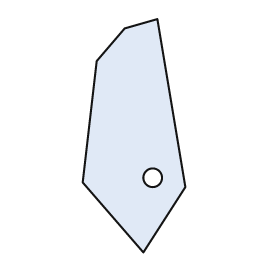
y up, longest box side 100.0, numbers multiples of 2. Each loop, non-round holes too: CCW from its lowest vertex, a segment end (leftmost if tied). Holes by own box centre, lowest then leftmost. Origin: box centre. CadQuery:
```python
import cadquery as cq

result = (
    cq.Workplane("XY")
    .moveTo(4.0, -50.0)
    .lineTo(22.0, -22.0)
    .lineTo(10.0, 50.0)
    .lineTo(-4.0, 46.0)
    .lineTo(-16.0, 32.0)
    .lineTo(-22.0, -20.0)
    .close()
    .moveTo(8.0, -18.0)
    .circle(4.0)
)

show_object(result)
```